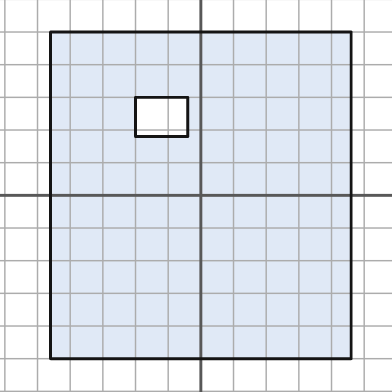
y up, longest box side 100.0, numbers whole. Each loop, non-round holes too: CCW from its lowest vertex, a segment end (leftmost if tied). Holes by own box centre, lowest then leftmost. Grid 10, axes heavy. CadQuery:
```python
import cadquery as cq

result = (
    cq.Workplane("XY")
    .moveTo(-46.0, -50.0)
    .lineTo(46.0, -50.0)
    .lineTo(46.0, 50.0)
    .lineTo(-46.0, 50.0)
    .close()
    .moveTo(-20.0, 18.0)
    .lineTo(-4.0, 18.0)
    .lineTo(-4.0, 30.0)
    .lineTo(-20.0, 30.0)
    .close()
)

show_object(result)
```